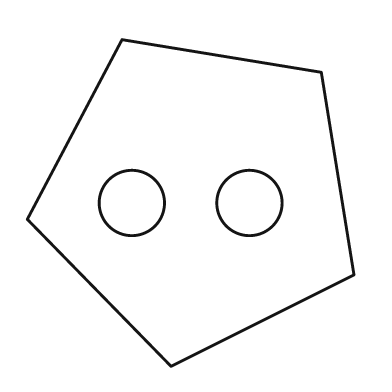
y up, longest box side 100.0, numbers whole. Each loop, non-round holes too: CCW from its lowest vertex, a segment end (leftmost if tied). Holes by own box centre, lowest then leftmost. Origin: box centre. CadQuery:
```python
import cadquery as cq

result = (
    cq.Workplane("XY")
    .moveTo(-6.0, -50.0)
    .lineTo(50.0, -22.0)
    .lineTo(40.0, 40.0)
    .lineTo(-21.0, 50.0)
    .lineTo(-50.0, -5.0)
    .close()
    .moveTo(-18.0, 0.0)
    .circle(10.0)
    .moveTo(18.0, 0.0)
    .circle(10.0)
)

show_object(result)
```